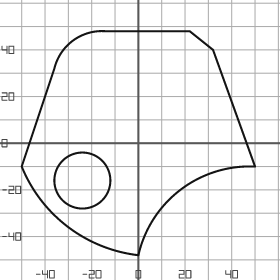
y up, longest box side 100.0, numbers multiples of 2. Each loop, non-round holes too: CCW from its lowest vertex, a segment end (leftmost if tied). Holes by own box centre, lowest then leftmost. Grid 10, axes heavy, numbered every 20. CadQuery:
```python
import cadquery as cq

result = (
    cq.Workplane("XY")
    .moveTo(0.0, -48.0)
    .threePointArc((18.0, -20.0), (50.0, -10.0))
    .lineTo(32.0, 40.0)
    .lineTo(22.0, 48.0)
    .lineTo(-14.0, 48.0)
    .threePointArc((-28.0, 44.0), (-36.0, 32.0))
    .lineTo(-50.0, -10.0)
    .threePointArc((-30.0, -36.0), (0.0, -48.0))
    .close()
    .moveTo(-24.0, -16.0)
    .circle(12.0)
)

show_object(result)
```